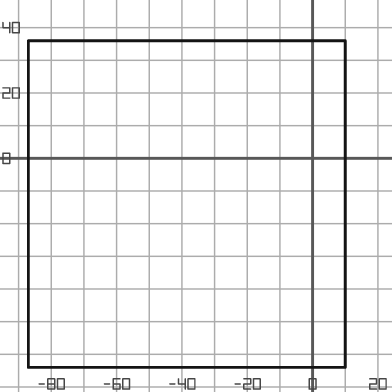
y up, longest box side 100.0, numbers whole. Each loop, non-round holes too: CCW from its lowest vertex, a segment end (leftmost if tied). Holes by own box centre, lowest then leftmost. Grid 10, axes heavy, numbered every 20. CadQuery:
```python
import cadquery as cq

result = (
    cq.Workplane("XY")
    .moveTo(-87.0, -64.0)
    .lineTo(10.0, -64.0)
    .lineTo(10.0, 36.0)
    .lineTo(-87.0, 36.0)
    .close()
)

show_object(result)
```